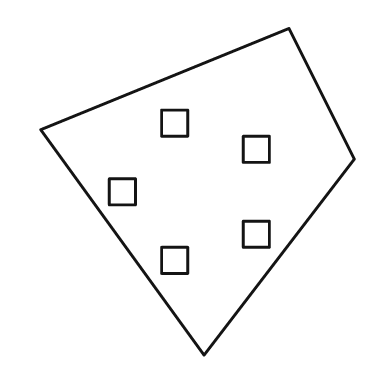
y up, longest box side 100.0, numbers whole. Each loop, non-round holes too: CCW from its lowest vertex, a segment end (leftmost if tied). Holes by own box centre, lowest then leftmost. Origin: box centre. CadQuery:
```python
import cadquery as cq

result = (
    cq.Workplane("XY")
    .moveTo(2.0, -50.0)
    .lineTo(48.0, 10.0)
    .lineTo(28.0, 50.0)
    .lineTo(-48.0, 19.0)
    .close()
    .moveTo(-11.0, -25.0)
    .lineTo(-3.0, -25.0)
    .lineTo(-3.0, -17.0)
    .lineTo(-11.0, -17.0)
    .close()
    .moveTo(14.0, -17.0)
    .lineTo(22.0, -17.0)
    .lineTo(22.0, -9.0)
    .lineTo(14.0, -9.0)
    .close()
    .moveTo(-27.0, -4.0)
    .lineTo(-19.0, -4.0)
    .lineTo(-19.0, 4.0)
    .lineTo(-27.0, 4.0)
    .close()
    .moveTo(14.0, 9.0)
    .lineTo(22.0, 9.0)
    .lineTo(22.0, 17.0)
    .lineTo(14.0, 17.0)
    .close()
    .moveTo(-11.0, 17.0)
    .lineTo(-3.0, 17.0)
    .lineTo(-3.0, 25.0)
    .lineTo(-11.0, 25.0)
    .close()
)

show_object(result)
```